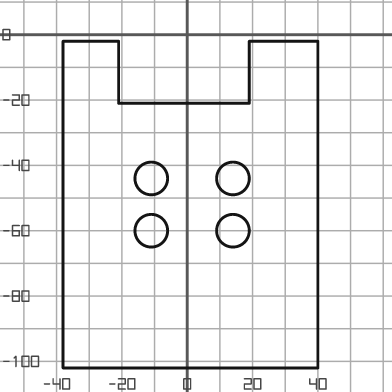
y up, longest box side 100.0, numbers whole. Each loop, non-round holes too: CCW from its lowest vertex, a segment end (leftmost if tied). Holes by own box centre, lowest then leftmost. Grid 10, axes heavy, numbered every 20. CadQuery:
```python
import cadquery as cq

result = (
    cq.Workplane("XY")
    .moveTo(-38.0, -102.0)
    .lineTo(40.0, -102.0)
    .lineTo(40.0, -2.0)
    .lineTo(19.0, -2.0)
    .lineTo(19.0, -21.0)
    .lineTo(-21.0, -21.0)
    .lineTo(-21.0, -2.0)
    .lineTo(-38.0, -2.0)
    .close()
    .moveTo(-11.0, -60.0)
    .circle(5.0)
    .moveTo(14.0, -60.0)
    .circle(5.0)
    .moveTo(-11.0, -44.0)
    .circle(5.0)
    .moveTo(14.0, -44.0)
    .circle(5.0)
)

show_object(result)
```